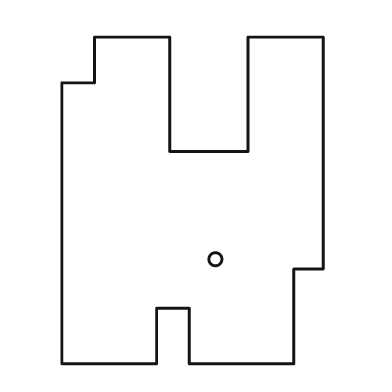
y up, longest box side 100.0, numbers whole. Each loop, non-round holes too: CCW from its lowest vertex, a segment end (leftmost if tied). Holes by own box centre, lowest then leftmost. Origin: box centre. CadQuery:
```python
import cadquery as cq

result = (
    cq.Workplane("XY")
    .moveTo(-40.0, -50.0)
    .lineTo(-11.0, -50.0)
    .lineTo(-11.0, -33.0)
    .lineTo(-1.0, -33.0)
    .lineTo(-1.0, -50.0)
    .lineTo(31.0, -50.0)
    .lineTo(31.0, -21.0)
    .lineTo(40.0, -21.0)
    .lineTo(40.0, 50.0)
    .lineTo(17.0, 50.0)
    .lineTo(17.0, 15.0)
    .lineTo(-7.0, 15.0)
    .lineTo(-7.0, 50.0)
    .lineTo(-30.0, 50.0)
    .lineTo(-30.0, 36.0)
    .lineTo(-40.0, 36.0)
    .close()
    .moveTo(7.0, -18.0)
    .circle(2.0)
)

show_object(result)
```